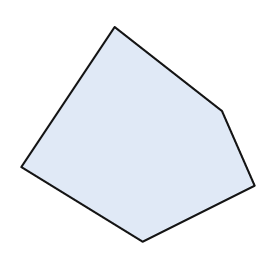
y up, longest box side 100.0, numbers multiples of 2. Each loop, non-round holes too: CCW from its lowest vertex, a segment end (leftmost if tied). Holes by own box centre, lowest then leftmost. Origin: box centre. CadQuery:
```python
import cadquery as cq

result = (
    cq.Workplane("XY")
    .moveTo(2.0, -46.0)
    .lineTo(50.0, -22.0)
    .lineTo(36.0, 10.0)
    .lineTo(-10.0, 46.0)
    .lineTo(-50.0, -14.0)
    .close()
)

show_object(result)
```